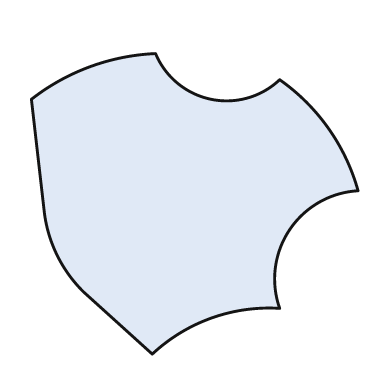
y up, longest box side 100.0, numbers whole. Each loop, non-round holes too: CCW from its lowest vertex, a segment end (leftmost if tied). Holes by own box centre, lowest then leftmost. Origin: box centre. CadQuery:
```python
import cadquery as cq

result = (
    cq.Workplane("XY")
    .moveTo(-13.0, -46.0)
    .threePointArc((5.0, -35.0), (26.0, -32.0))
    .threePointArc((29.0, -8.0), (50.0, 4.0))
    .threePointArc((41.0, 23.0), (26.0, 38.0))
    .threePointArc((5.0, 32.0), (-12.0, 46.0))
    .threePointArc((-32.0, 42.0), (-50.0, 32.0))
    .lineTo(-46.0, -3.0)
    .threePointArc((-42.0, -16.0), (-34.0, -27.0))
    .close()
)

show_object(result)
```